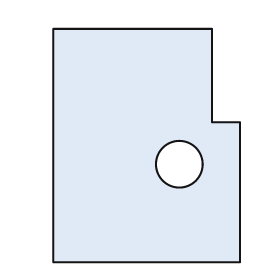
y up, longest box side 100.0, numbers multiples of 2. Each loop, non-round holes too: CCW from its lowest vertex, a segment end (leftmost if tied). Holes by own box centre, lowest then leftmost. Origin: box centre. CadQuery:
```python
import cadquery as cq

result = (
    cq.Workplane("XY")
    .moveTo(-40.0, -50.0)
    .lineTo(40.0, -50.0)
    .lineTo(40.0, 10.0)
    .lineTo(28.0, 10.0)
    .lineTo(28.0, 50.0)
    .lineTo(-40.0, 50.0)
    .close()
    .moveTo(14.0, -8.0)
    .circle(10.0)
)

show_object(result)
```